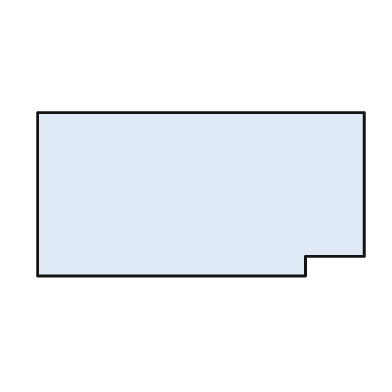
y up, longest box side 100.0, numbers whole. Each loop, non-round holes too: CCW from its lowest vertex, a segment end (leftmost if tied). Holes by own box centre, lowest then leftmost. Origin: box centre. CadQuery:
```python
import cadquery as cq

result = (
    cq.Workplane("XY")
    .moveTo(-50.0, -25.0)
    .lineTo(32.0, -25.0)
    .lineTo(32.0, -19.0)
    .lineTo(50.0, -19.0)
    .lineTo(50.0, 25.0)
    .lineTo(-50.0, 25.0)
    .close()
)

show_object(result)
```